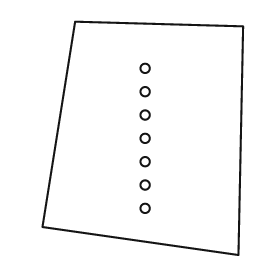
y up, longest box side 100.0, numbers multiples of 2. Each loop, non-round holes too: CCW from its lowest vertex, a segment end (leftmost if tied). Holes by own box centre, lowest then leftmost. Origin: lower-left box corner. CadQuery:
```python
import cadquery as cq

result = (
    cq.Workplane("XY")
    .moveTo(84.0, 0.0)
    .lineTo(86.0, 98.0)
    .lineTo(14.0, 100.0)
    .lineTo(0.0, 12.0)
    .close()
    .moveTo(44.0, 20.0)
    .circle(2.0)
    .moveTo(44.0, 30.0)
    .circle(2.0)
    .moveTo(44.0, 40.0)
    .circle(2.0)
    .moveTo(44.0, 50.0)
    .circle(2.0)
    .moveTo(44.0, 60.0)
    .circle(2.0)
    .moveTo(44.0, 70.0)
    .circle(2.0)
    .moveTo(44.0, 80.0)
    .circle(2.0)
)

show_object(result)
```